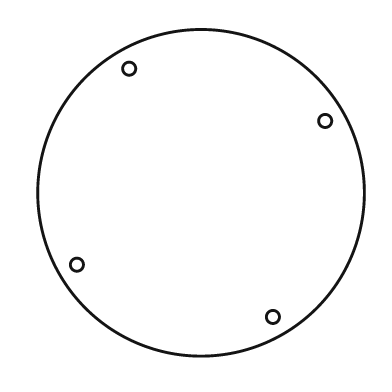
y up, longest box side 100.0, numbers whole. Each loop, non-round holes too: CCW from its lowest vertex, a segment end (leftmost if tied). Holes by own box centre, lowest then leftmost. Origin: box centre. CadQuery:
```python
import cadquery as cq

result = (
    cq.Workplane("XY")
    .moveTo(0.0, 0.0)
    .circle(50.0)
    .moveTo(22.0, -38.0)
    .circle(2.0)
    .moveTo(-38.0, -22.0)
    .circle(2.0)
    .moveTo(38.0, 22.0)
    .circle(2.0)
    .moveTo(-22.0, 38.0)
    .circle(2.0)
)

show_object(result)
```